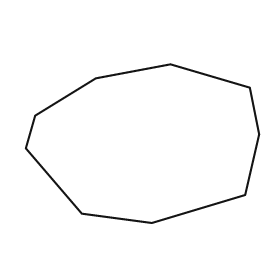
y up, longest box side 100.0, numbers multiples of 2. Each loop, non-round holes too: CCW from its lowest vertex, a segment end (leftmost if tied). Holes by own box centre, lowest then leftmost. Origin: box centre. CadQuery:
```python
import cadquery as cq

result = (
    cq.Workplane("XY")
    .moveTo(4.0, -34.0)
    .lineTo(44.0, -22.0)
    .lineTo(50.0, 4.0)
    .lineTo(46.0, 24.0)
    .lineTo(12.0, 34.0)
    .lineTo(-20.0, 28.0)
    .lineTo(-46.0, 12.0)
    .lineTo(-50.0, -2.0)
    .lineTo(-26.0, -30.0)
    .close()
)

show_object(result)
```